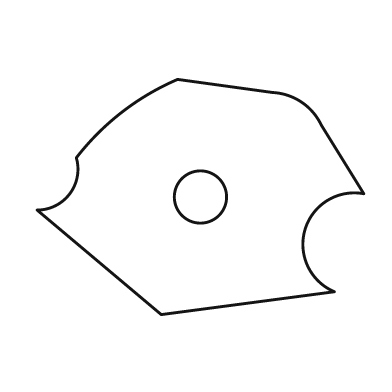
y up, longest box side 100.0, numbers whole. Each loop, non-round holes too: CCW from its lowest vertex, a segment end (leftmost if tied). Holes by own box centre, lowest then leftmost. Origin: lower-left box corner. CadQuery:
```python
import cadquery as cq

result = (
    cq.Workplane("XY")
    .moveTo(38.0, 0.0)
    .lineTo(91.0, 7.0)
    .threePointArc((82.0, 26.0), (100.0, 37.0))
    .lineTo(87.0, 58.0)
    .threePointArc((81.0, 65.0), (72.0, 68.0))
    .lineTo(43.0, 72.0)
    .threePointArc((26.0, 62.0), (12.0, 48.0))
    .threePointArc((10.0, 37.0), (0.0, 32.0))
    .close()
    .moveTo(50.0, 36.0)
    .circle(8.0)
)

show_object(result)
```